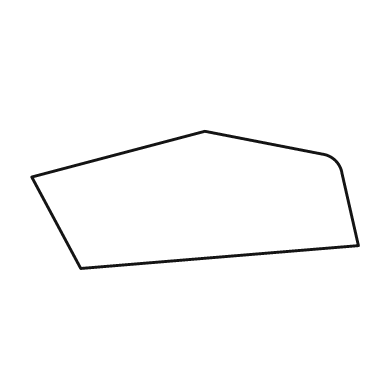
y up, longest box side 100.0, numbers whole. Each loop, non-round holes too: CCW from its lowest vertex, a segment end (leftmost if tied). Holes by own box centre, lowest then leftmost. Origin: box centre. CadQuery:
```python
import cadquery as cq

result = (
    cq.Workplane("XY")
    .moveTo(-35.0, -21.0)
    .lineTo(50.0, -14.0)
    .lineTo(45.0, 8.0)
    .threePointArc((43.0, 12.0), (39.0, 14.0))
    .lineTo(3.0, 21.0)
    .lineTo(-50.0, 7.0)
    .close()
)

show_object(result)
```